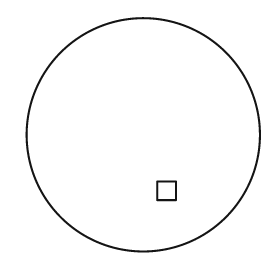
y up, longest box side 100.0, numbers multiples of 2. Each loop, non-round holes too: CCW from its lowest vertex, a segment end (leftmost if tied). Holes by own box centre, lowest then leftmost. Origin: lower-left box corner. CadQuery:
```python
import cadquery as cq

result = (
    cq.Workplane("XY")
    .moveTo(50.0, 50.0)
    .circle(50.0)
    .moveTo(56.0, 22.0)
    .lineTo(64.0, 22.0)
    .lineTo(64.0, 30.0)
    .lineTo(56.0, 30.0)
    .close()
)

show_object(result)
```